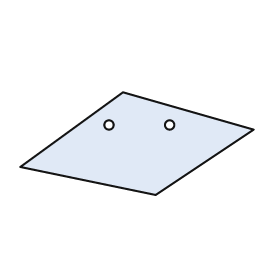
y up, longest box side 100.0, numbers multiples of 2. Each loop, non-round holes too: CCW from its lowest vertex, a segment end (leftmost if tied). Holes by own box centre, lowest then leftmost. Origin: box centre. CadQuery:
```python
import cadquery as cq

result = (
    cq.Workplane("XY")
    .moveTo(8.0, -22.0)
    .lineTo(50.0, 6.0)
    .lineTo(-6.0, 22.0)
    .lineTo(-50.0, -10.0)
    .close()
    .moveTo(-12.0, 8.0)
    .circle(2.0)
    .moveTo(14.0, 8.0)
    .circle(2.0)
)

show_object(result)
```